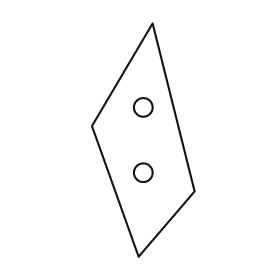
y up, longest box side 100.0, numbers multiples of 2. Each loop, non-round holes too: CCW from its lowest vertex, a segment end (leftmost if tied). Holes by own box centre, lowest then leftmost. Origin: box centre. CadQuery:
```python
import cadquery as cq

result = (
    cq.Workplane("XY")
    .moveTo(-2.0, -50.0)
    .lineTo(22.0, -22.0)
    .lineTo(4.0, 50.0)
    .lineTo(-22.0, 6.0)
    .close()
    .moveTo(0.0, -14.0)
    .circle(4.0)
    .moveTo(0.0, 14.0)
    .circle(4.0)
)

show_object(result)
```